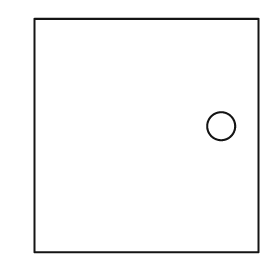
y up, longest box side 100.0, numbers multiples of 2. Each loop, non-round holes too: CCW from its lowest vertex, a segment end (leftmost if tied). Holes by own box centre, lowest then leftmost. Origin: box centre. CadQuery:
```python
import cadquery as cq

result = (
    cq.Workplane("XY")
    .moveTo(-48.0, -50.0)
    .lineTo(48.0, -50.0)
    .lineTo(48.0, 50.0)
    .lineTo(-48.0, 50.0)
    .close()
    .moveTo(32.0, 4.0)
    .circle(6.0)
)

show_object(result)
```